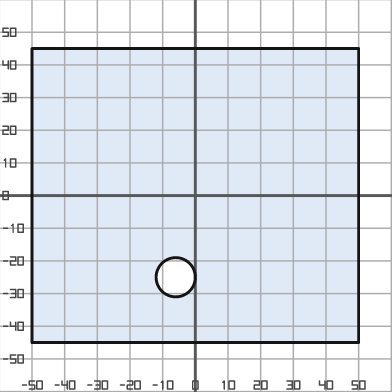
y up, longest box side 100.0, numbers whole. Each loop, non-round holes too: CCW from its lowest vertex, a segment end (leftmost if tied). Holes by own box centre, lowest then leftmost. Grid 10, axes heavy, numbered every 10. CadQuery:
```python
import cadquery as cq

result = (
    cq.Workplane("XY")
    .moveTo(-50.0, -45.0)
    .lineTo(50.0, -45.0)
    .lineTo(50.0, 45.0)
    .lineTo(-50.0, 45.0)
    .close()
    .moveTo(-6.0, -25.0)
    .circle(6.0)
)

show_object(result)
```